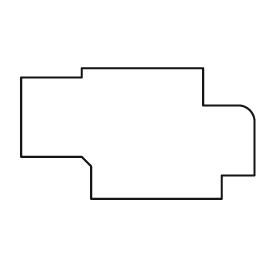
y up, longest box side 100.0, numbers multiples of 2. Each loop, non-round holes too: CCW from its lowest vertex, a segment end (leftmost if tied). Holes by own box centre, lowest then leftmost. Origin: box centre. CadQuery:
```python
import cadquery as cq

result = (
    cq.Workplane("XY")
    .moveTo(-20.0, -28.0)
    .lineTo(36.0, -28.0)
    .lineTo(36.0, -18.0)
    .lineTo(50.0, -18.0)
    .lineTo(50.0, 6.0)
    .threePointArc((48.0, 10.0), (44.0, 12.0))
    .lineTo(28.0, 12.0)
    .lineTo(28.0, 28.0)
    .lineTo(-24.0, 28.0)
    .lineTo(-24.0, 24.0)
    .lineTo(-50.0, 24.0)
    .lineTo(-50.0, -10.0)
    .lineTo(-24.0, -10.0)
    .lineTo(-20.0, -14.0)
    .close()
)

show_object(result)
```